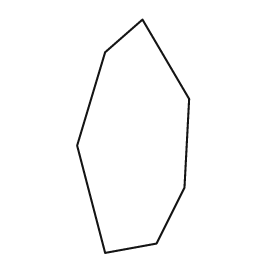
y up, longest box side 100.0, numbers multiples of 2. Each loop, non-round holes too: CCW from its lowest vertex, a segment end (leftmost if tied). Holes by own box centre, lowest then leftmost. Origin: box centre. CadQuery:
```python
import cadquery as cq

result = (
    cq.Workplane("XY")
    .moveTo(-12.0, -50.0)
    .lineTo(10.0, -46.0)
    .lineTo(22.0, -22.0)
    .lineTo(24.0, 16.0)
    .lineTo(4.0, 50.0)
    .lineTo(-12.0, 36.0)
    .lineTo(-24.0, -4.0)
    .close()
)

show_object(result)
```